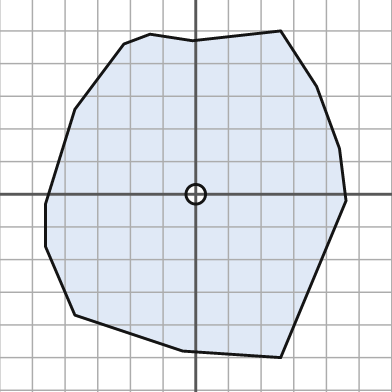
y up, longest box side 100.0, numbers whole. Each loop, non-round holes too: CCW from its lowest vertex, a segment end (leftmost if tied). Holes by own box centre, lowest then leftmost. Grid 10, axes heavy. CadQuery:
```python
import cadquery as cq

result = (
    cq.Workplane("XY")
    .moveTo(26.0, -50.0)
    .lineTo(46.0, -2.0)
    .lineTo(44.0, 14.0)
    .lineTo(37.0, 33.0)
    .lineTo(26.0, 50.0)
    .lineTo(-1.0, 47.0)
    .lineTo(-14.0, 49.0)
    .lineTo(-22.0, 46.0)
    .lineTo(-37.0, 26.0)
    .lineTo(-46.0, -3.0)
    .lineTo(-46.0, -16.0)
    .lineTo(-37.0, -37.0)
    .lineTo(-4.0, -48.0)
    .close()
    .moveTo(0.0, 0.0)
    .circle(3.0)
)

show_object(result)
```